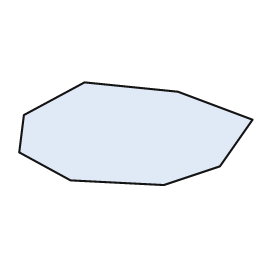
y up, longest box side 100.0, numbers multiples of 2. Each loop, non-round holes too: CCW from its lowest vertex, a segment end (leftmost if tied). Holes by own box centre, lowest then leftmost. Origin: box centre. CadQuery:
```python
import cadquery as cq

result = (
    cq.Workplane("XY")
    .moveTo(12.0, -22.0)
    .lineTo(36.0, -14.0)
    .lineTo(50.0, 6.0)
    .lineTo(18.0, 18.0)
    .lineTo(-22.0, 22.0)
    .lineTo(-48.0, 8.0)
    .lineTo(-50.0, -8.0)
    .lineTo(-28.0, -20.0)
    .close()
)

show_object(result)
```